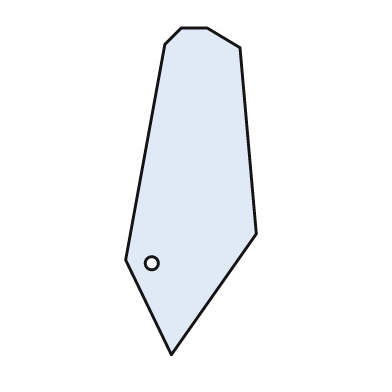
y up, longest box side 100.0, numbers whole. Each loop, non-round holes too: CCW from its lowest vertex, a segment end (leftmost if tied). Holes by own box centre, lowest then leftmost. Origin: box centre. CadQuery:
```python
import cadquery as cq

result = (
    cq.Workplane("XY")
    .moveTo(-6.0, -50.0)
    .lineTo(20.0, -13.0)
    .lineTo(15.0, 44.0)
    .lineTo(5.0, 50.0)
    .lineTo(-3.0, 50.0)
    .lineTo(-8.0, 45.0)
    .lineTo(-20.0, -21.0)
    .close()
    .moveTo(-12.0, -22.0)
    .circle(2.0)
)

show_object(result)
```